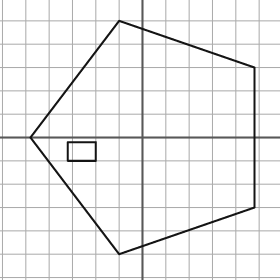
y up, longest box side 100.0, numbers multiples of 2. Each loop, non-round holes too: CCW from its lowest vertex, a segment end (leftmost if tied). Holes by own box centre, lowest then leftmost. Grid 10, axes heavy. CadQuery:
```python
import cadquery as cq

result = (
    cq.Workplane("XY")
    .moveTo(-10.0, -50.0)
    .lineTo(48.0, -30.0)
    .lineTo(48.0, 30.0)
    .lineTo(-10.0, 50.0)
    .lineTo(-48.0, 0.0)
    .close()
    .moveTo(-32.0, -10.0)
    .lineTo(-20.0, -10.0)
    .lineTo(-20.0, -2.0)
    .lineTo(-32.0, -2.0)
    .close()
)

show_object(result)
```